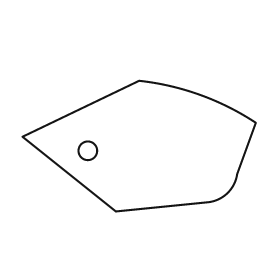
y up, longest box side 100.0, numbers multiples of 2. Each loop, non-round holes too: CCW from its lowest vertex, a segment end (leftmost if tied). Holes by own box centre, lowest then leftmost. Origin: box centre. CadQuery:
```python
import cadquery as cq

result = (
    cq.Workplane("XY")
    .moveTo(-10.0, -28.0)
    .lineTo(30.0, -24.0)
    .threePointArc((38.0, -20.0), (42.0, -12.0))
    .lineTo(50.0, 10.0)
    .threePointArc((26.0, 22.0), (0.0, 28.0))
    .lineTo(-50.0, 4.0)
    .close()
    .moveTo(-22.0, -2.0)
    .circle(4.0)
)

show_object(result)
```